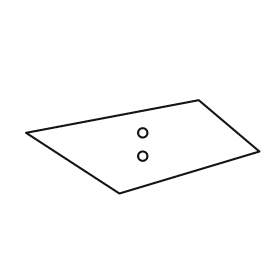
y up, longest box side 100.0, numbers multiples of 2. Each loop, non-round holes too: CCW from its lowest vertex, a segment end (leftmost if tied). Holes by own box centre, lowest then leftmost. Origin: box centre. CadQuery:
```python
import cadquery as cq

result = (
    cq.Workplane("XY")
    .moveTo(-10.0, -20.0)
    .lineTo(50.0, -2.0)
    .lineTo(24.0, 20.0)
    .lineTo(-50.0, 6.0)
    .close()
    .moveTo(0.0, -4.0)
    .circle(2.0)
    .moveTo(0.0, 6.0)
    .circle(2.0)
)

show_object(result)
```